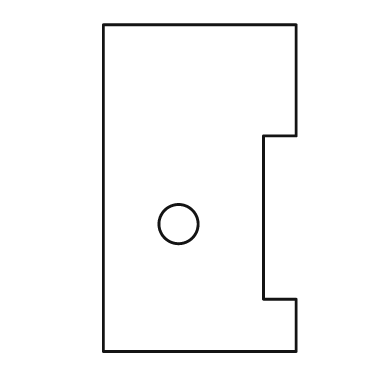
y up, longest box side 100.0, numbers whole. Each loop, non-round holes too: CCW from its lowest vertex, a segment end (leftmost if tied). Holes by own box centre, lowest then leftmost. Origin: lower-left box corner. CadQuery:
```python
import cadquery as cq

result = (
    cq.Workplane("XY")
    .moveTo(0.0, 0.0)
    .lineTo(59.0, 0.0)
    .lineTo(59.0, 16.0)
    .lineTo(49.0, 16.0)
    .lineTo(49.0, 66.0)
    .lineTo(59.0, 66.0)
    .lineTo(59.0, 100.0)
    .lineTo(0.0, 100.0)
    .close()
    .moveTo(23.0, 39.0)
    .circle(6.0)
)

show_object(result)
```